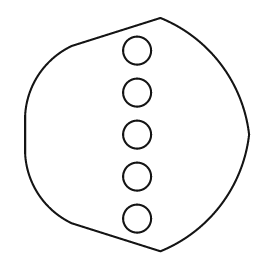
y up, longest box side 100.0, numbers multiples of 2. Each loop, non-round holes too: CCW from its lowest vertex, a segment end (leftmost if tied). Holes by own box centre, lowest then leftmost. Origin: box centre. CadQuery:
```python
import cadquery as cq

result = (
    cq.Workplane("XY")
    .moveTo(10.0, -50.0)
    .threePointArc((36.0, -30.0), (48.0, 0.0))
    .threePointArc((36.0, 30.0), (10.0, 50.0))
    .lineTo(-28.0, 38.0)
    .threePointArc((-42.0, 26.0), (-48.0, 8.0))
    .lineTo(-48.0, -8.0)
    .threePointArc((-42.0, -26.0), (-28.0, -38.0))
    .close()
    .moveTo(0.0, -36.0)
    .circle(6.0)
    .moveTo(0.0, -18.0)
    .circle(6.0)
    .moveTo(0.0, 0.0)
    .circle(6.0)
    .moveTo(0.0, 18.0)
    .circle(6.0)
    .moveTo(0.0, 36.0)
    .circle(6.0)
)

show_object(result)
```